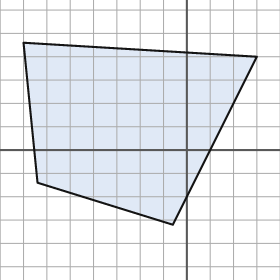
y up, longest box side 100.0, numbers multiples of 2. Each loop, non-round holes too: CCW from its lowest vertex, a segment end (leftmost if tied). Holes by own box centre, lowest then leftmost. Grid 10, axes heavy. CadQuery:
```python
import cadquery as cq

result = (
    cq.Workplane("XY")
    .moveTo(-6.0, -32.0)
    .lineTo(30.0, 40.0)
    .lineTo(-70.0, 46.0)
    .lineTo(-64.0, -14.0)
    .close()
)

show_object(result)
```